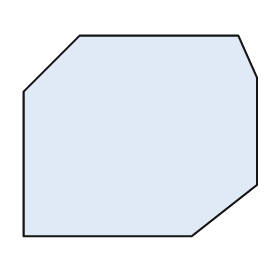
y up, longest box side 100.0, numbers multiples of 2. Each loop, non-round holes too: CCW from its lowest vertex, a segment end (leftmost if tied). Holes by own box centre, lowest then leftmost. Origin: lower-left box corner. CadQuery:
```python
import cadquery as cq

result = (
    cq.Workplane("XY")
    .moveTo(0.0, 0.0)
    .lineTo(72.0, 0.0)
    .lineTo(100.0, 22.0)
    .lineTo(100.0, 68.0)
    .lineTo(92.0, 86.0)
    .lineTo(24.0, 86.0)
    .lineTo(0.0, 62.0)
    .close()
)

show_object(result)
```